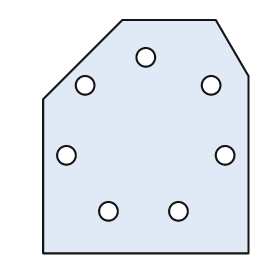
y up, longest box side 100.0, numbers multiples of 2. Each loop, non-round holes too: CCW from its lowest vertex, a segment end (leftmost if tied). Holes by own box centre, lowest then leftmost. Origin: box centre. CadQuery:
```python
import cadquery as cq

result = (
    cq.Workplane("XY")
    .moveTo(-44.0, -50.0)
    .lineTo(44.0, -50.0)
    .lineTo(44.0, 26.0)
    .lineTo(30.0, 50.0)
    .lineTo(-10.0, 50.0)
    .lineTo(-44.0, 16.0)
    .close()
    .moveTo(-16.0, -32.0)
    .circle(4.0)
    .moveTo(14.0, -32.0)
    .circle(4.0)
    .moveTo(-34.0, -8.0)
    .circle(4.0)
    .moveTo(34.0, -8.0)
    .circle(4.0)
    .moveTo(-26.0, 22.0)
    .circle(4.0)
    .moveTo(28.0, 22.0)
    .circle(4.0)
    .moveTo(0.0, 34.0)
    .circle(4.0)
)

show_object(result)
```